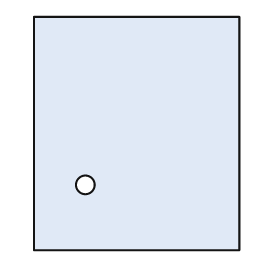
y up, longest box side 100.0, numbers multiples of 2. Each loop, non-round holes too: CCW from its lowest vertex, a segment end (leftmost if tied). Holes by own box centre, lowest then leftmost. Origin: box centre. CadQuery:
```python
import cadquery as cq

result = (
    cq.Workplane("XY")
    .moveTo(-44.0, -50.0)
    .lineTo(44.0, -50.0)
    .lineTo(44.0, 50.0)
    .lineTo(-44.0, 50.0)
    .close()
    .moveTo(-22.0, -22.0)
    .circle(4.0)
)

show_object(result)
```